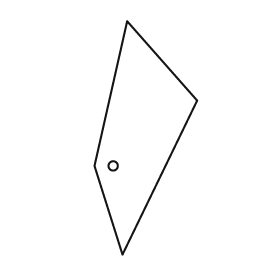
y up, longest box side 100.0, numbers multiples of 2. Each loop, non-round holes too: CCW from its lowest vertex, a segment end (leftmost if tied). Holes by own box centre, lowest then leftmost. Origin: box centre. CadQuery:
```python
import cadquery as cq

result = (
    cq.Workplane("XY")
    .moveTo(-10.0, -50.0)
    .lineTo(22.0, 16.0)
    .lineTo(-8.0, 50.0)
    .lineTo(-22.0, -12.0)
    .close()
    .moveTo(-14.0, -12.0)
    .circle(2.0)
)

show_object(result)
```